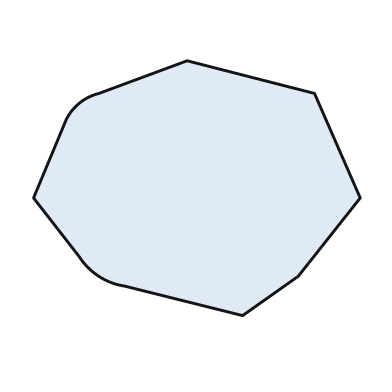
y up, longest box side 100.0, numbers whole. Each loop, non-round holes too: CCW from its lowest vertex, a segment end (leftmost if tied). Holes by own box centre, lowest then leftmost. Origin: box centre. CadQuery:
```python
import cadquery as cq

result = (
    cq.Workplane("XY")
    .moveTo(14.0, -39.0)
    .lineTo(31.0, -27.0)
    .lineTo(50.0, -3.0)
    .lineTo(36.0, 29.0)
    .lineTo(-3.0, 39.0)
    .lineTo(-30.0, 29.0)
    .threePointArc((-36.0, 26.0), (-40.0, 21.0))
    .lineTo(-50.0, -3.0)
    .lineTo(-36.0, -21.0)
    .threePointArc((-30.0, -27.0), (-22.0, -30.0))
    .close()
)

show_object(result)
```